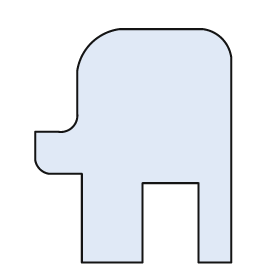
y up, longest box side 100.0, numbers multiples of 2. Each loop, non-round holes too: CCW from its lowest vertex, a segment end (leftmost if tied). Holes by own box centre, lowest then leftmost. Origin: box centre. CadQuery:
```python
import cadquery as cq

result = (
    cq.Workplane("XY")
    .moveTo(-22.0, -50.0)
    .lineTo(4.0, -50.0)
    .lineTo(4.0, -16.0)
    .lineTo(28.0, -16.0)
    .lineTo(28.0, -50.0)
    .lineTo(42.0, -50.0)
    .lineTo(42.0, 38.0)
    .threePointArc((38.0, 46.0), (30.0, 50.0))
    .lineTo(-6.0, 50.0)
    .threePointArc((-18.0, 44.0), (-24.0, 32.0))
    .lineTo(-24.0, 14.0)
    .threePointArc((-26.0, 8.0), (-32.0, 6.0))
    .lineTo(-42.0, 6.0)
    .lineTo(-42.0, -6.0)
    .threePointArc((-40.0, -10.0), (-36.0, -12.0))
    .lineTo(-22.0, -12.0)
    .close()
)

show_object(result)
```